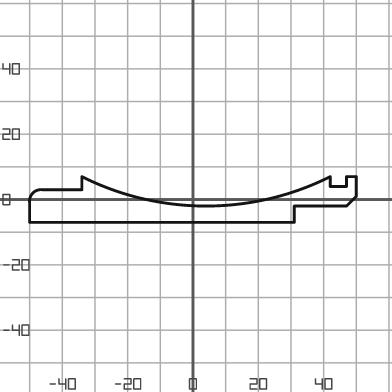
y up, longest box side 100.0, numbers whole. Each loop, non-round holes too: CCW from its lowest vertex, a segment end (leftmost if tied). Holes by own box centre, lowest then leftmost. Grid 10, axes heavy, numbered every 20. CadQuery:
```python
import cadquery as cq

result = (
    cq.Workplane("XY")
    .moveTo(-50.0, -7.0)
    .lineTo(31.0, -7.0)
    .lineTo(31.0, -2.0)
    .lineTo(47.0, -2.0)
    .lineTo(50.0, 1.0)
    .lineTo(50.0, 7.0)
    .lineTo(47.0, 7.0)
    .lineTo(47.0, 4.0)
    .lineTo(42.0, 4.0)
    .lineTo(42.0, 7.0)
    .threePointArc((4.0, -2.0), (-34.0, 7.0))
    .lineTo(-34.0, 3.0)
    .lineTo(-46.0, 3.0)
    .threePointArc((-49.0, 2.0), (-50.0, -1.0))
    .close()
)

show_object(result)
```